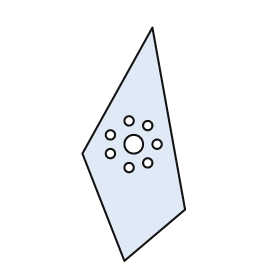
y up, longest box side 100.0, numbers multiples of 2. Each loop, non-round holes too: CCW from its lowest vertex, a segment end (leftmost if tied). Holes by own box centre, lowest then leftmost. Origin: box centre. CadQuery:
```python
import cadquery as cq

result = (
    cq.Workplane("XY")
    .moveTo(-4.0, -50.0)
    .lineTo(22.0, -28.0)
    .lineTo(8.0, 50.0)
    .lineTo(-22.0, -4.0)
    .close()
    .moveTo(-2.0, -10.0)
    .circle(2.0)
    .moveTo(6.0, -8.0)
    .circle(2.0)
    .moveTo(-10.0, -4.0)
    .circle(2.0)
    .moveTo(0.0, 0.0)
    .circle(4.0)
    .moveTo(10.0, 0.0)
    .circle(2.0)
    .moveTo(-10.0, 4.0)
    .circle(2.0)
    .moveTo(6.0, 8.0)
    .circle(2.0)
    .moveTo(-2.0, 10.0)
    .circle(2.0)
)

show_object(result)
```